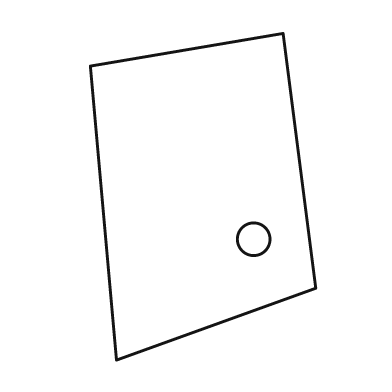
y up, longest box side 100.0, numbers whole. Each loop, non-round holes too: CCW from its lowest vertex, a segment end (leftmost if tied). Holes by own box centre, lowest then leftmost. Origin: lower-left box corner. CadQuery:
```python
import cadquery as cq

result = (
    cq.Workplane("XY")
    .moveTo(8.0, 0.0)
    .lineTo(69.0, 22.0)
    .lineTo(59.0, 100.0)
    .lineTo(0.0, 90.0)
    .close()
    .moveTo(50.0, 37.0)
    .circle(5.0)
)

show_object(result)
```